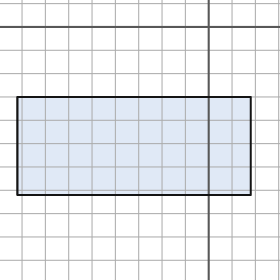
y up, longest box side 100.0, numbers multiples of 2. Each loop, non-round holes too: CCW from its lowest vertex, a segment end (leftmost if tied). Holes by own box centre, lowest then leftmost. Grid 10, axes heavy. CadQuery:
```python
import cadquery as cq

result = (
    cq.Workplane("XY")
    .moveTo(-82.0, -72.0)
    .lineTo(18.0, -72.0)
    .lineTo(18.0, -30.0)
    .lineTo(-82.0, -30.0)
    .close()
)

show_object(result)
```